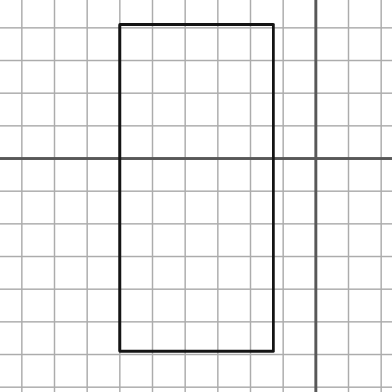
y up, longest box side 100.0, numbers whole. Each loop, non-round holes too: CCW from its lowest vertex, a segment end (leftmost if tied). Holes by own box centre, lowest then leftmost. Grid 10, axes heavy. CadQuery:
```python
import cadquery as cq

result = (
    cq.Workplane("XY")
    .moveTo(-60.0, -59.0)
    .lineTo(-13.0, -59.0)
    .lineTo(-13.0, 41.0)
    .lineTo(-60.0, 41.0)
    .close()
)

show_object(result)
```